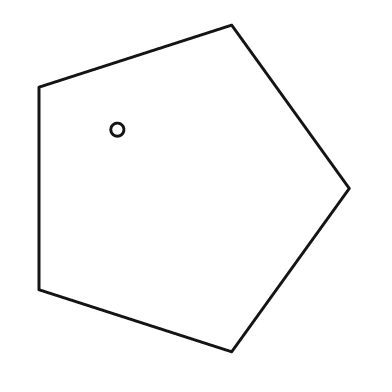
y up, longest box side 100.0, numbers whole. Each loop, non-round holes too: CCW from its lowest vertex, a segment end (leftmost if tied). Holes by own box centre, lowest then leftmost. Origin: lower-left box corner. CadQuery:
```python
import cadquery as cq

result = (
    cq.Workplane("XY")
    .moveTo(59.0, 0.0)
    .lineTo(95.0, 50.0)
    .lineTo(59.0, 100.0)
    .lineTo(0.0, 81.0)
    .lineTo(0.0, 19.0)
    .close()
    .moveTo(24.0, 68.0)
    .circle(2.0)
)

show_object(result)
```